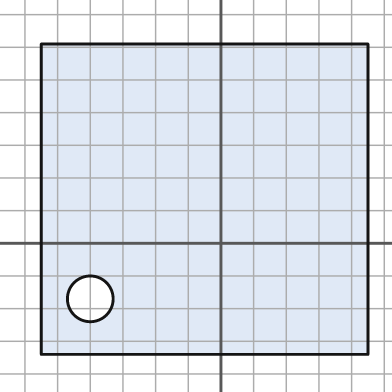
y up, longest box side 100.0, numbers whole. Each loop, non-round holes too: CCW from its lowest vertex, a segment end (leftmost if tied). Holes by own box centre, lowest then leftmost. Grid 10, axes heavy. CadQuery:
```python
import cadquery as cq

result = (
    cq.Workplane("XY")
    .moveTo(-55.0, -34.0)
    .lineTo(45.0, -34.0)
    .lineTo(45.0, 61.0)
    .lineTo(-55.0, 61.0)
    .close()
    .moveTo(-40.0, -17.0)
    .circle(7.0)
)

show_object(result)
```